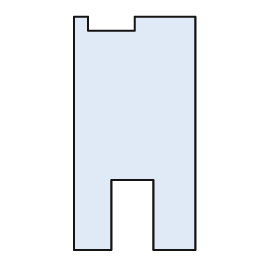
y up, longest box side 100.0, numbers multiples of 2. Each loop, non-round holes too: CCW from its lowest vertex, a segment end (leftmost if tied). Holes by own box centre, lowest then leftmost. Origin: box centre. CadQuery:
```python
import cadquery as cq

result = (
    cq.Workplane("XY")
    .moveTo(-26.0, -50.0)
    .lineTo(-10.0, -50.0)
    .lineTo(-10.0, -20.0)
    .lineTo(8.0, -20.0)
    .lineTo(8.0, -50.0)
    .lineTo(26.0, -50.0)
    .lineTo(26.0, 50.0)
    .lineTo(0.0, 50.0)
    .lineTo(0.0, 44.0)
    .lineTo(-20.0, 44.0)
    .lineTo(-20.0, 50.0)
    .lineTo(-26.0, 50.0)
    .close()
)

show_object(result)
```